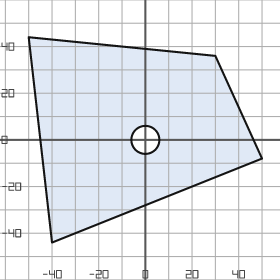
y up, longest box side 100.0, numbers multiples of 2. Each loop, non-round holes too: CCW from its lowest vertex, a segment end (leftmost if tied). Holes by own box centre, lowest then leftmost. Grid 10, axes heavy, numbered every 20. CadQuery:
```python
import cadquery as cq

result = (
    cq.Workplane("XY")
    .moveTo(-40.0, -44.0)
    .lineTo(50.0, -8.0)
    .lineTo(30.0, 36.0)
    .lineTo(-50.0, 44.0)
    .close()
    .moveTo(0.0, 0.0)
    .circle(6.0)
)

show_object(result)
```